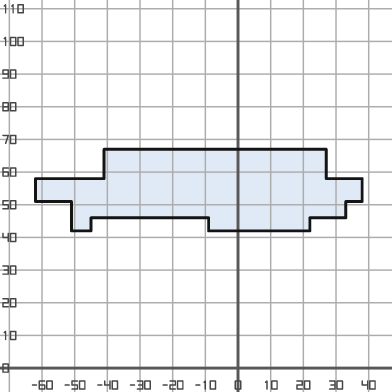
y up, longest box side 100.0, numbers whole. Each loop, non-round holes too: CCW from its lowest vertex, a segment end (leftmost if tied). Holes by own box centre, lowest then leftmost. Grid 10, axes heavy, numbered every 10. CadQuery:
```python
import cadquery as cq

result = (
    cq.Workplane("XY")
    .moveTo(-51.0, 42.0)
    .lineTo(-45.0, 42.0)
    .lineTo(-45.0, 46.0)
    .lineTo(-9.0, 46.0)
    .lineTo(-9.0, 42.0)
    .lineTo(22.0, 42.0)
    .lineTo(22.0, 46.0)
    .lineTo(33.0, 46.0)
    .lineTo(33.0, 51.0)
    .lineTo(38.0, 51.0)
    .lineTo(38.0, 58.0)
    .lineTo(27.0, 58.0)
    .lineTo(27.0, 67.0)
    .lineTo(-41.0, 67.0)
    .lineTo(-41.0, 58.0)
    .lineTo(-62.0, 58.0)
    .lineTo(-62.0, 51.0)
    .lineTo(-51.0, 51.0)
    .close()
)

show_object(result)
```